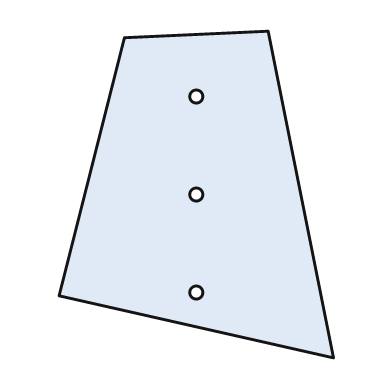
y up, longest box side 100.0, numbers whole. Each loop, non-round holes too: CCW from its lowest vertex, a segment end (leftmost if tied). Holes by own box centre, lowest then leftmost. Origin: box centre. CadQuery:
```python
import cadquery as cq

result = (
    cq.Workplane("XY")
    .moveTo(42.0, -50.0)
    .lineTo(22.0, 50.0)
    .lineTo(-22.0, 48.0)
    .lineTo(-42.0, -31.0)
    .close()
    .moveTo(0.0, -30.0)
    .circle(2.0)
    .moveTo(0.0, 0.0)
    .circle(2.0)
    .moveTo(0.0, 30.0)
    .circle(2.0)
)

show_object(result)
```